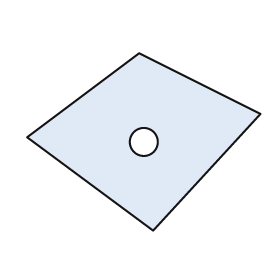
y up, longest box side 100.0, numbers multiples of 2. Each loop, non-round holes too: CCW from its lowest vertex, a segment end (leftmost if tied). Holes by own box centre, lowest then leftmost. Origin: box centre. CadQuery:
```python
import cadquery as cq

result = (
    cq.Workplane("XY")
    .moveTo(4.0, -38.0)
    .lineTo(50.0, 12.0)
    .lineTo(-2.0, 38.0)
    .lineTo(-50.0, 2.0)
    .close()
    .moveTo(0.0, 0.0)
    .circle(6.0)
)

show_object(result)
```